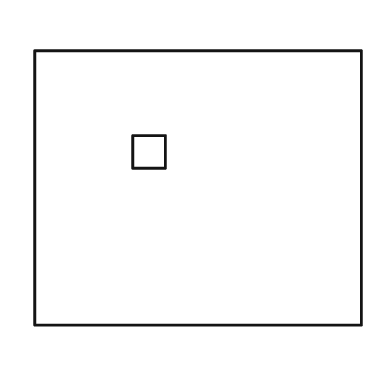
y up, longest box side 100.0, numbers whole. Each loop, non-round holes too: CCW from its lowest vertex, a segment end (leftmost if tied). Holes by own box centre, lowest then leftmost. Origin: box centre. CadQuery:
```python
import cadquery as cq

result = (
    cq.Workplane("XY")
    .moveTo(-50.0, -42.0)
    .lineTo(50.0, -42.0)
    .lineTo(50.0, 42.0)
    .lineTo(-50.0, 42.0)
    .close()
    .moveTo(-20.0, 6.0)
    .lineTo(-10.0, 6.0)
    .lineTo(-10.0, 16.0)
    .lineTo(-20.0, 16.0)
    .close()
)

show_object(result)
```